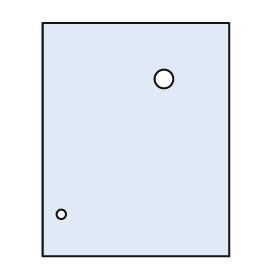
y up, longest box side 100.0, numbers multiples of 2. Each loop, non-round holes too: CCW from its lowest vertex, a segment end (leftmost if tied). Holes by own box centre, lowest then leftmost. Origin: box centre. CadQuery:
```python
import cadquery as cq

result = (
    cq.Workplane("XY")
    .moveTo(-40.0, -50.0)
    .lineTo(40.0, -50.0)
    .lineTo(40.0, 50.0)
    .lineTo(-40.0, 50.0)
    .close()
    .moveTo(-32.0, -32.0)
    .circle(2.0)
    .moveTo(12.0, 26.0)
    .circle(4.0)
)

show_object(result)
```